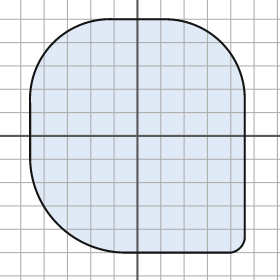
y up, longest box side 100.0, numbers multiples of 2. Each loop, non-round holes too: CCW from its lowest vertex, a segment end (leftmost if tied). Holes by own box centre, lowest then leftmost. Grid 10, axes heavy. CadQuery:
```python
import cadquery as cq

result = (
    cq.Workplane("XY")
    .moveTo(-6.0, -50.0)
    .lineTo(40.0, -50.0)
    .threePointArc((44.0, -48.0), (46.0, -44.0))
    .lineTo(46.0, 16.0)
    .threePointArc((36.0, 40.0), (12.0, 50.0))
    .lineTo(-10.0, 50.0)
    .threePointArc((-36.0, 40.0), (-46.0, 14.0))
    .lineTo(-46.0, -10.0)
    .threePointArc((-34.0, -38.0), (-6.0, -50.0))
    .close()
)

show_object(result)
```